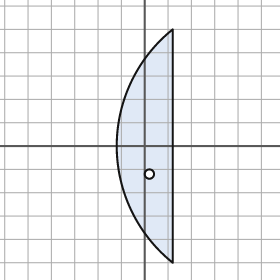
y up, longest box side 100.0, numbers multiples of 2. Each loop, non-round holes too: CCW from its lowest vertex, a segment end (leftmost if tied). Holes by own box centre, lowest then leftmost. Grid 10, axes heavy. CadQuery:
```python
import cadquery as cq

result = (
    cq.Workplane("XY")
    .moveTo(12.0, -50.0)
    .lineTo(12.0, 50.0)
    .threePointArc((-12.0, 0.0), (12.0, -50.0))
    .close()
    .moveTo(2.0, -12.0)
    .circle(2.0)
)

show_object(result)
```